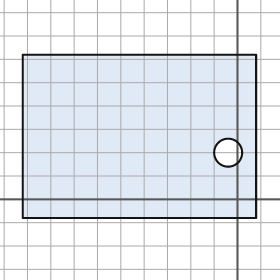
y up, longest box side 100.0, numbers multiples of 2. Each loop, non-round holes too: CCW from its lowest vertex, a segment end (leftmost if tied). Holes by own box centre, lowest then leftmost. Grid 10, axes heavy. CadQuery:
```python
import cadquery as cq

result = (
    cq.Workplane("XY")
    .moveTo(-92.0, -8.0)
    .lineTo(8.0, -8.0)
    .lineTo(8.0, 62.0)
    .lineTo(-92.0, 62.0)
    .close()
    .moveTo(-4.0, 20.0)
    .circle(6.0)
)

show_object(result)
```